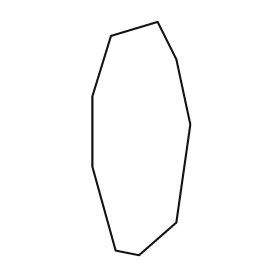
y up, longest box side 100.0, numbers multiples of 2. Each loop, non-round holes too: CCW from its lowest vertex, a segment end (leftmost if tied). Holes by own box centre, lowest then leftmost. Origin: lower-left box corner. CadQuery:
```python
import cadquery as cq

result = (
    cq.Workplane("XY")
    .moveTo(20.0, 0.0)
    .lineTo(36.0, 14.0)
    .lineTo(42.0, 56.0)
    .lineTo(36.0, 84.0)
    .lineTo(28.0, 100.0)
    .lineTo(8.0, 94.0)
    .lineTo(0.0, 68.0)
    .lineTo(0.0, 38.0)
    .lineTo(10.0, 2.0)
    .close()
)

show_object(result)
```